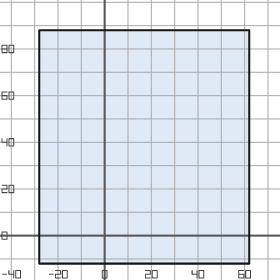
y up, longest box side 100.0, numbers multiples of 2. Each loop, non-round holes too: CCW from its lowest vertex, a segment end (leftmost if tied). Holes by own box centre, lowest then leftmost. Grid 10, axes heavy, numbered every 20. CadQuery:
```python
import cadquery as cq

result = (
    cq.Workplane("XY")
    .moveTo(-28.0, -12.0)
    .lineTo(62.0, -12.0)
    .lineTo(62.0, 88.0)
    .lineTo(-28.0, 88.0)
    .close()
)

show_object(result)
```